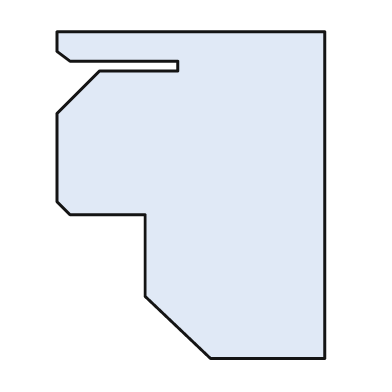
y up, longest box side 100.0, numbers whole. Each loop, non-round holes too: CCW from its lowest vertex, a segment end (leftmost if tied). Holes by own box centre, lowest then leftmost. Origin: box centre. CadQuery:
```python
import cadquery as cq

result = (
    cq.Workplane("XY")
    .moveTo(6.0, -50.0)
    .lineTo(41.0, -50.0)
    .lineTo(41.0, 50.0)
    .lineTo(-41.0, 50.0)
    .lineTo(-41.0, 44.0)
    .lineTo(-37.0, 41.0)
    .lineTo(-4.0, 41.0)
    .lineTo(-4.0, 38.0)
    .lineTo(-28.0, 38.0)
    .lineTo(-41.0, 25.0)
    .lineTo(-41.0, -2.0)
    .lineTo(-37.0, -6.0)
    .lineTo(-14.0, -6.0)
    .lineTo(-14.0, -31.0)
    .close()
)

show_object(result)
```